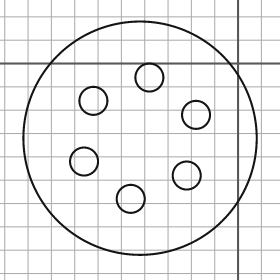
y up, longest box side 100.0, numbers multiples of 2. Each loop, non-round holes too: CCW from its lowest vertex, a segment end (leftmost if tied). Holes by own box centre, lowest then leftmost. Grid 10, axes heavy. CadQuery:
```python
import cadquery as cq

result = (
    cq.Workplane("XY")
    .moveTo(-42.0, -32.0)
    .circle(50.0)
    .moveTo(-46.0, -58.0)
    .circle(6.0)
    .moveTo(-22.0, -48.0)
    .circle(6.0)
    .moveTo(-66.0, -42.0)
    .circle(6.0)
    .moveTo(-18.0, -22.0)
    .circle(6.0)
    .moveTo(-62.0, -16.0)
    .circle(6.0)
    .moveTo(-38.0, -6.0)
    .circle(6.0)
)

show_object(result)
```